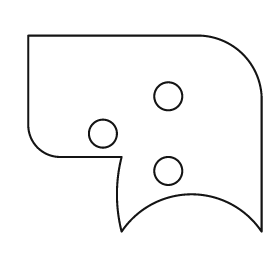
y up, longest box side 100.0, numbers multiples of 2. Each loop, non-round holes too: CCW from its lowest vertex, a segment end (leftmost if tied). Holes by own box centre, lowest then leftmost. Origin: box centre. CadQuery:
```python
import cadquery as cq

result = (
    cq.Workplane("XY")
    .moveTo(-10.0, -42.0)
    .threePointArc((20.0, -26.0), (50.0, -42.0))
    .lineTo(50.0, 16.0)
    .threePointArc((42.0, 34.0), (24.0, 42.0))
    .lineTo(-50.0, 42.0)
    .lineTo(-50.0, 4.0)
    .threePointArc((-46.0, -6.0), (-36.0, -10.0))
    .lineTo(-10.0, -10.0)
    .threePointArc((-12.0, -26.0), (-10.0, -42.0))
    .close()
    .moveTo(10.0, -16.0)
    .circle(6.0)
    .moveTo(-18.0, 0.0)
    .circle(6.0)
    .moveTo(10.0, 16.0)
    .circle(6.0)
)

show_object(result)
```